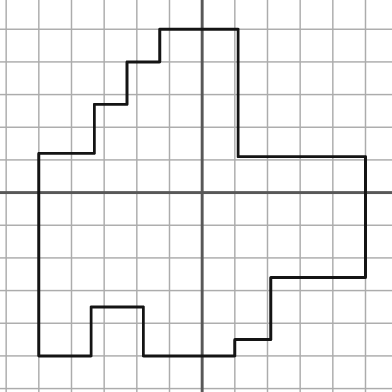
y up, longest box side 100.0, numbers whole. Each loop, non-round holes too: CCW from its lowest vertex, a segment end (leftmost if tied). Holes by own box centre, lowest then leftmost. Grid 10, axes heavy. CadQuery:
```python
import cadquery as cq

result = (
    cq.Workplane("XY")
    .moveTo(-50.0, -50.0)
    .lineTo(-34.0, -50.0)
    .lineTo(-34.0, -35.0)
    .lineTo(-18.0, -35.0)
    .lineTo(-18.0, -50.0)
    .lineTo(10.0, -50.0)
    .lineTo(10.0, -45.0)
    .lineTo(21.0, -45.0)
    .lineTo(21.0, -26.0)
    .lineTo(50.0, -26.0)
    .lineTo(50.0, 11.0)
    .lineTo(11.0, 11.0)
    .lineTo(11.0, 50.0)
    .lineTo(-13.0, 50.0)
    .lineTo(-13.0, 40.0)
    .lineTo(-23.0, 40.0)
    .lineTo(-23.0, 27.0)
    .lineTo(-33.0, 27.0)
    .lineTo(-33.0, 12.0)
    .lineTo(-50.0, 12.0)
    .close()
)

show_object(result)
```